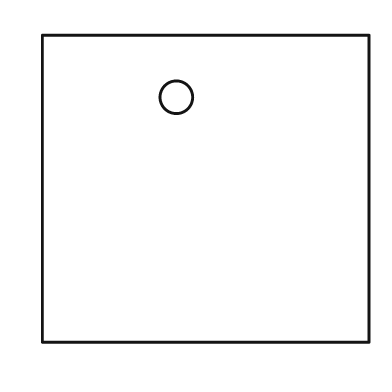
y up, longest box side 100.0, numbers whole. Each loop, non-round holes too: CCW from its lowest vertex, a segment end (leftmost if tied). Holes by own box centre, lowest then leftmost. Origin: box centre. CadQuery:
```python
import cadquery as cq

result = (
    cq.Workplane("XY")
    .moveTo(-50.0, -47.0)
    .lineTo(50.0, -47.0)
    .lineTo(50.0, 47.0)
    .lineTo(-50.0, 47.0)
    .close()
    .moveTo(-9.0, 28.0)
    .circle(5.0)
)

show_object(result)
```